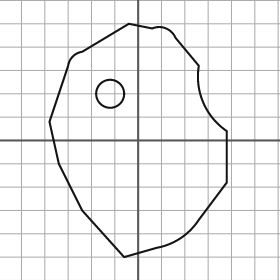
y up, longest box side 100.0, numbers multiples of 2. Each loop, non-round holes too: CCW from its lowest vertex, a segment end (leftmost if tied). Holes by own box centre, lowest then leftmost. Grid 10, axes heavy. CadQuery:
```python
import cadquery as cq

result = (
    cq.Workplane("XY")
    .moveTo(-6.0, -50.0)
    .lineTo(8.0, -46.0)
    .threePointArc((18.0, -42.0), (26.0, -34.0))
    .lineTo(38.0, -18.0)
    .lineTo(38.0, 4.0)
    .threePointArc((28.0, 16.0), (26.0, 32.0))
    .lineTo(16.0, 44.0)
    .threePointArc((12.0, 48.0), (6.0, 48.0))
    .lineTo(-4.0, 50.0)
    .lineTo(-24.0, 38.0)
    .threePointArc((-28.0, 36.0), (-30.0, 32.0))
    .lineTo(-38.0, 8.0)
    .lineTo(-34.0, -10.0)
    .lineTo(-24.0, -30.0)
    .close()
    .moveTo(-12.0, 20.0)
    .circle(6.0)
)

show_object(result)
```